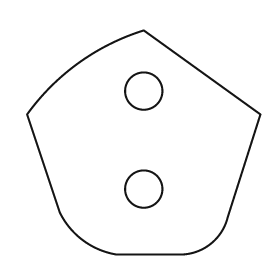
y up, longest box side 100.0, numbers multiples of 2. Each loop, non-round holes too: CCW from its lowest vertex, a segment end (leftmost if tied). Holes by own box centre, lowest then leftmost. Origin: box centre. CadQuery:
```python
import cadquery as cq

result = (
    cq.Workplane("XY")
    .moveTo(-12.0, -48.0)
    .lineTo(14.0, -48.0)
    .threePointArc((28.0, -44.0), (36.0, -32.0))
    .lineTo(50.0, 12.0)
    .lineTo(0.0, 48.0)
    .threePointArc((-28.0, 34.0), (-50.0, 12.0))
    .lineTo(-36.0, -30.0)
    .threePointArc((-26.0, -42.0), (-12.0, -48.0))
    .close()
    .moveTo(0.0, -20.0)
    .circle(8.0)
    .moveTo(0.0, 22.0)
    .circle(8.0)
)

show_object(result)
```